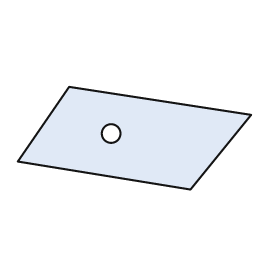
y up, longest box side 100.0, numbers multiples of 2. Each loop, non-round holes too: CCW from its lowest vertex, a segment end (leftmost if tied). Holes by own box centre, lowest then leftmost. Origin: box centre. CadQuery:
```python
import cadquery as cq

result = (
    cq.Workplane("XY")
    .moveTo(24.0, -22.0)
    .lineTo(50.0, 10.0)
    .lineTo(-28.0, 22.0)
    .lineTo(-50.0, -10.0)
    .close()
    .moveTo(-10.0, 2.0)
    .circle(4.0)
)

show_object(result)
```